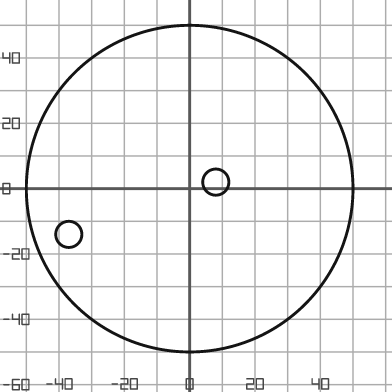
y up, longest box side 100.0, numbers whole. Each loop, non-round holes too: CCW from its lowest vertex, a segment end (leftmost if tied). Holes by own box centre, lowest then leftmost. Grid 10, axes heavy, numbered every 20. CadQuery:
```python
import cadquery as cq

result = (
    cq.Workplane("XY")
    .moveTo(0.0, 0.0)
    .circle(50.0)
    .moveTo(-37.0, -14.0)
    .circle(4.0)
    .moveTo(8.0, 2.0)
    .circle(4.0)
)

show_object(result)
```